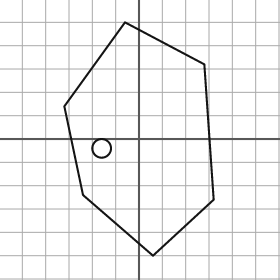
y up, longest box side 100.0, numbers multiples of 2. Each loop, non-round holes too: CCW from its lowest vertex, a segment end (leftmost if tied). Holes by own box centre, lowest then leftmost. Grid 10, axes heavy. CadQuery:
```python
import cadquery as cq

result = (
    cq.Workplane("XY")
    .moveTo(6.0, -50.0)
    .lineTo(32.0, -26.0)
    .lineTo(28.0, 32.0)
    .lineTo(-6.0, 50.0)
    .lineTo(-32.0, 14.0)
    .lineTo(-24.0, -24.0)
    .close()
    .moveTo(-16.0, -4.0)
    .circle(4.0)
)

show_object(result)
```